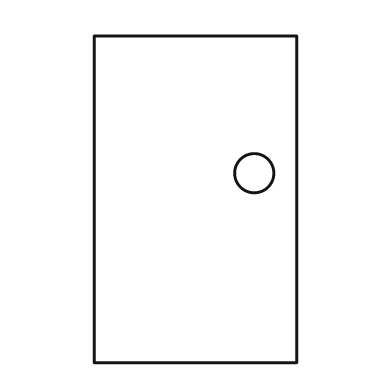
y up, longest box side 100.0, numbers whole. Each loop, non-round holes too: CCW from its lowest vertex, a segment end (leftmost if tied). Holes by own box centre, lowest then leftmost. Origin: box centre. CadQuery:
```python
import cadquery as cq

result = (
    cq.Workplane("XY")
    .moveTo(-31.0, -50.0)
    .lineTo(31.0, -50.0)
    .lineTo(31.0, 50.0)
    .lineTo(-31.0, 50.0)
    .close()
    .moveTo(18.0, 8.0)
    .circle(6.0)
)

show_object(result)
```